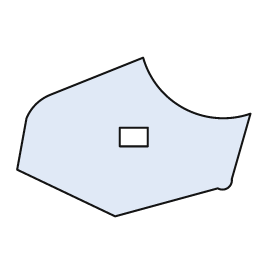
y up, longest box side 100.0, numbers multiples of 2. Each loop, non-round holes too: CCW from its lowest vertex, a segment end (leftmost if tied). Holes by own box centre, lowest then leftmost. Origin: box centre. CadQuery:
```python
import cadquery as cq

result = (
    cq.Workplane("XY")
    .moveTo(-8.0, -34.0)
    .lineTo(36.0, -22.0)
    .threePointArc((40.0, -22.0), (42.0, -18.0))
    .lineTo(50.0, 10.0)
    .threePointArc((22.0, 12.0), (4.0, 34.0))
    .lineTo(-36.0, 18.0)
    .threePointArc((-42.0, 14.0), (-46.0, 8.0))
    .lineTo(-50.0, -14.0)
    .close()
    .moveTo(-6.0, -4.0)
    .lineTo(6.0, -4.0)
    .lineTo(6.0, 4.0)
    .lineTo(-6.0, 4.0)
    .close()
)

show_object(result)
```